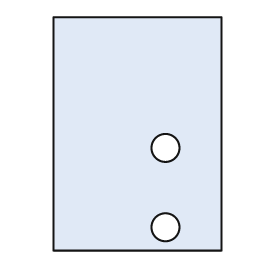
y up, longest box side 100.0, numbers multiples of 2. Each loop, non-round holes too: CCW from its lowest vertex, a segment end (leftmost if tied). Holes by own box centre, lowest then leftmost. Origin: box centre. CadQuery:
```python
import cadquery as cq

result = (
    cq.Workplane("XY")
    .moveTo(-36.0, -50.0)
    .lineTo(36.0, -50.0)
    .lineTo(36.0, 50.0)
    .lineTo(-36.0, 50.0)
    .close()
    .moveTo(12.0, -40.0)
    .circle(6.0)
    .moveTo(12.0, -6.0)
    .circle(6.0)
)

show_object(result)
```